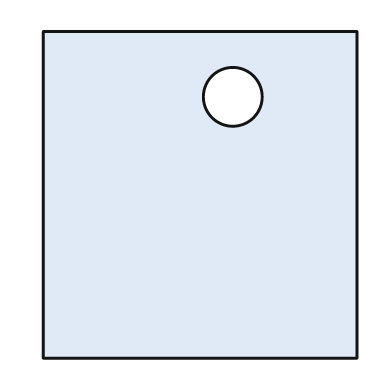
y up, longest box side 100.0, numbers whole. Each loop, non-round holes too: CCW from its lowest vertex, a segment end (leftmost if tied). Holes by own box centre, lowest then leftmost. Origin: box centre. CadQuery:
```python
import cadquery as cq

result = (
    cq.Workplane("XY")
    .moveTo(-48.0, -50.0)
    .lineTo(48.0, -50.0)
    .lineTo(48.0, 50.0)
    .lineTo(-48.0, 50.0)
    .close()
    .moveTo(10.0, 30.0)
    .circle(9.0)
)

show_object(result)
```